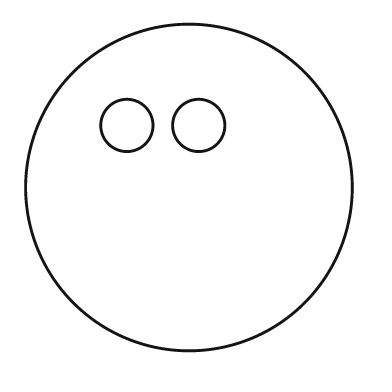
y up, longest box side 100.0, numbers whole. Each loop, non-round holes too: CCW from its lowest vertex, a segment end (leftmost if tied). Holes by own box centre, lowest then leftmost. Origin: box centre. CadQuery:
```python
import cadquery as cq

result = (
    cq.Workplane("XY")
    .moveTo(0.0, 0.0)
    .circle(50.0)
    .moveTo(-19.0, 19.0)
    .circle(8.0)
    .moveTo(3.0, 19.0)
    .circle(8.0)
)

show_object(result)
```